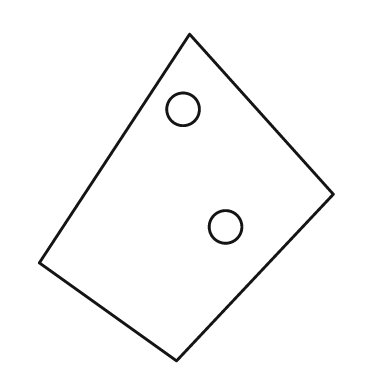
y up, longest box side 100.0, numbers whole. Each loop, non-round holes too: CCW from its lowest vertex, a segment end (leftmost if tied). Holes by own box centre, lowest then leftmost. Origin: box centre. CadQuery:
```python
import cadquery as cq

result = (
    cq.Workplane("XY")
    .moveTo(-3.0, -50.0)
    .lineTo(45.0, 1.0)
    .lineTo(1.0, 50.0)
    .lineTo(-45.0, -20.0)
    .close()
    .moveTo(12.0, -9.0)
    .circle(5.0)
    .moveTo(-1.0, 27.0)
    .circle(5.0)
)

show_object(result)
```